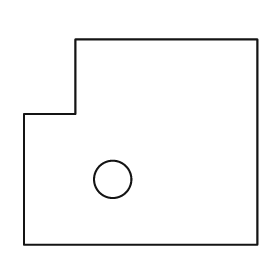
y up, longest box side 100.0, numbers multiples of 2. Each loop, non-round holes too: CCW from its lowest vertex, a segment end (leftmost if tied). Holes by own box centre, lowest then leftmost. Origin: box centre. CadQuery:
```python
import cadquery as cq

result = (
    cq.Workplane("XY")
    .moveTo(-50.0, -44.0)
    .lineTo(50.0, -44.0)
    .lineTo(50.0, 44.0)
    .lineTo(-28.0, 44.0)
    .lineTo(-28.0, 12.0)
    .lineTo(-50.0, 12.0)
    .close()
    .moveTo(-12.0, -16.0)
    .circle(8.0)
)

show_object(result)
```